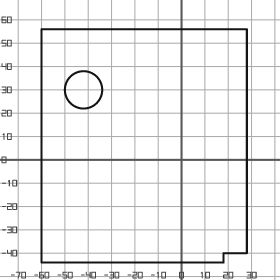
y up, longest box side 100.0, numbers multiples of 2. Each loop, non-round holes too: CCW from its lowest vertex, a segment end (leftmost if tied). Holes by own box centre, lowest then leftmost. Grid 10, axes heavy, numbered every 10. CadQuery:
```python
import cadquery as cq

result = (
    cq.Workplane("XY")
    .moveTo(-60.0, -44.0)
    .lineTo(18.0, -44.0)
    .lineTo(18.0, -40.0)
    .lineTo(28.0, -40.0)
    .lineTo(28.0, 56.0)
    .lineTo(-60.0, 56.0)
    .close()
    .moveTo(-42.0, 30.0)
    .circle(8.0)
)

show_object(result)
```